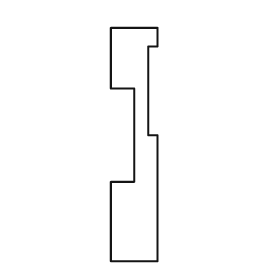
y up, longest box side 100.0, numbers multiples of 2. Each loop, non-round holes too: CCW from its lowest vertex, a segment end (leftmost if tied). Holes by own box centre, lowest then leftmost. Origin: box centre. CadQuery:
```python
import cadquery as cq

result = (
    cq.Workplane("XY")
    .moveTo(-10.0, -50.0)
    .lineTo(10.0, -50.0)
    .lineTo(10.0, 4.0)
    .lineTo(6.0, 4.0)
    .lineTo(6.0, 42.0)
    .lineTo(10.0, 42.0)
    .lineTo(10.0, 50.0)
    .lineTo(-10.0, 50.0)
    .lineTo(-10.0, 24.0)
    .lineTo(0.0, 24.0)
    .lineTo(0.0, -16.0)
    .lineTo(-10.0, -16.0)
    .close()
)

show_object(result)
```